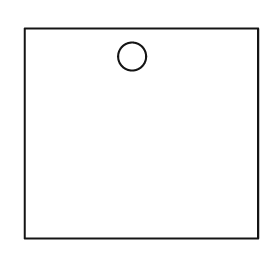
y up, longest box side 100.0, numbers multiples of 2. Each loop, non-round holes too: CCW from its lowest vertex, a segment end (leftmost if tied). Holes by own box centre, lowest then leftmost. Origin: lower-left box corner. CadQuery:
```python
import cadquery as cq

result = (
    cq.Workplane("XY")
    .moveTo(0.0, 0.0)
    .lineTo(100.0, 0.0)
    .lineTo(100.0, 90.0)
    .lineTo(0.0, 90.0)
    .close()
    .moveTo(46.0, 78.0)
    .circle(6.0)
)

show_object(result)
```